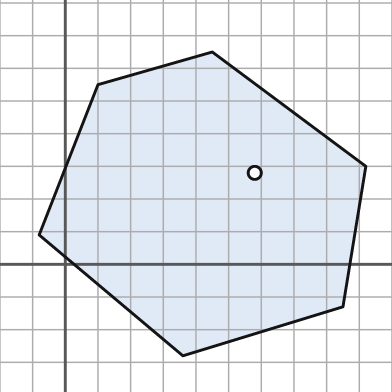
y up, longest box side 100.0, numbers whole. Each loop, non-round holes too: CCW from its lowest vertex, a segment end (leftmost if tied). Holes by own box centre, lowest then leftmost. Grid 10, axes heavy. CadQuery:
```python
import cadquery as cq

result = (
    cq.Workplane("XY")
    .moveTo(36.0, -28.0)
    .lineTo(85.0, -13.0)
    .lineTo(92.0, 30.0)
    .lineTo(45.0, 65.0)
    .lineTo(10.0, 55.0)
    .lineTo(-8.0, 9.0)
    .close()
    .moveTo(58.0, 28.0)
    .circle(2.0)
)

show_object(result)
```